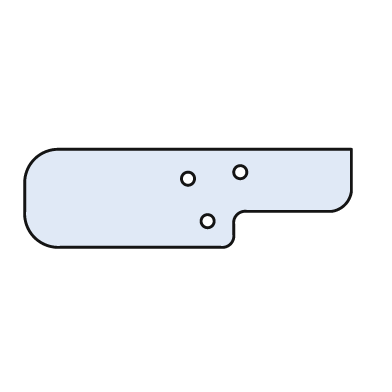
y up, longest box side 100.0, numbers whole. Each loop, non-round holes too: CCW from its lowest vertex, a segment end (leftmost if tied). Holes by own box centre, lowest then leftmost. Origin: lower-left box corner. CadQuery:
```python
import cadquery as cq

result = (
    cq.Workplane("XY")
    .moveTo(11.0, 0.0)
    .lineTo(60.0, 0.0)
    .threePointArc((63.0, 1.0), (64.0, 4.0))
    .lineTo(64.0, 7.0)
    .threePointArc((65.0, 10.0), (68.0, 11.0))
    .lineTo(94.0, 11.0)
    .threePointArc((98.0, 13.0), (100.0, 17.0))
    .lineTo(100.0, 30.0)
    .lineTo(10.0, 30.0)
    .threePointArc((3.0, 27.0), (0.0, 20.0))
    .lineTo(0.0, 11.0)
    .threePointArc((3.0, 3.0), (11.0, 0.0))
    .close()
    .moveTo(56.0, 8.0)
    .circle(2.0)
    .moveTo(50.0, 21.0)
    .circle(2.0)
    .moveTo(66.0, 23.0)
    .circle(2.0)
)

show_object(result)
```